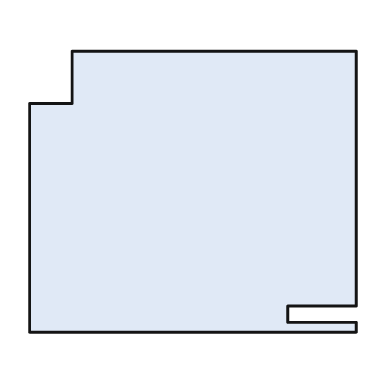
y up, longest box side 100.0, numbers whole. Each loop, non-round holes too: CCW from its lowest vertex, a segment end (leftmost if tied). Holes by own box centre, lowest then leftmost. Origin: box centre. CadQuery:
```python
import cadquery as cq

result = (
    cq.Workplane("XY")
    .moveTo(-50.0, -43.0)
    .lineTo(50.0, -43.0)
    .lineTo(50.0, -40.0)
    .lineTo(29.0, -40.0)
    .lineTo(29.0, -35.0)
    .lineTo(50.0, -35.0)
    .lineTo(50.0, 43.0)
    .lineTo(-37.0, 43.0)
    .lineTo(-37.0, 27.0)
    .lineTo(-50.0, 27.0)
    .close()
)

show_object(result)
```